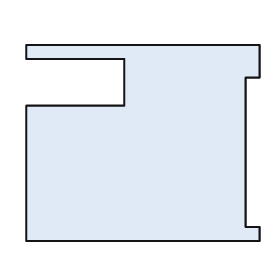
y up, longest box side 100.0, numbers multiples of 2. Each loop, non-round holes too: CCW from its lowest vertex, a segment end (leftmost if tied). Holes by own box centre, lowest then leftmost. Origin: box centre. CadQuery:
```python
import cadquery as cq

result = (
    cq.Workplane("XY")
    .moveTo(-50.0, -42.0)
    .lineTo(50.0, -42.0)
    .lineTo(50.0, -36.0)
    .lineTo(44.0, -36.0)
    .lineTo(44.0, 28.0)
    .lineTo(50.0, 28.0)
    .lineTo(50.0, 42.0)
    .lineTo(-50.0, 42.0)
    .lineTo(-50.0, 36.0)
    .lineTo(-8.0, 36.0)
    .lineTo(-8.0, 16.0)
    .lineTo(-50.0, 16.0)
    .close()
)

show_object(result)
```